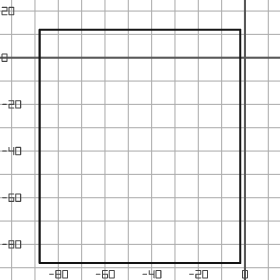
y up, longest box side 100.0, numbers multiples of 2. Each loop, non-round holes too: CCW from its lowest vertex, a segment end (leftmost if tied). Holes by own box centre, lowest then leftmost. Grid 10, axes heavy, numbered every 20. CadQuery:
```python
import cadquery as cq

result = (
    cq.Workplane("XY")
    .moveTo(-88.0, -88.0)
    .lineTo(-2.0, -88.0)
    .lineTo(-2.0, 12.0)
    .lineTo(-88.0, 12.0)
    .close()
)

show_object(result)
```